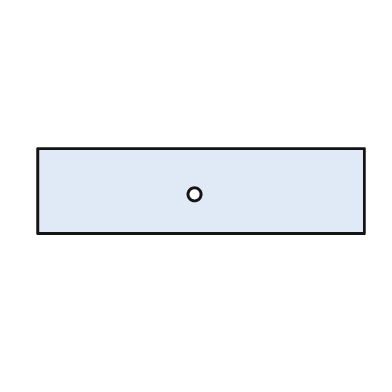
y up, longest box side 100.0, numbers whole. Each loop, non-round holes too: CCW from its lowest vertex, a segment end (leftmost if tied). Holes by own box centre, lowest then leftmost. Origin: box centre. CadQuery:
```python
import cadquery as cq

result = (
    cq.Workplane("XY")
    .moveTo(-50.0, -13.0)
    .lineTo(50.0, -13.0)
    .lineTo(50.0, 13.0)
    .lineTo(-50.0, 13.0)
    .close()
    .moveTo(-2.0, -1.0)
    .circle(2.0)
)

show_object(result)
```